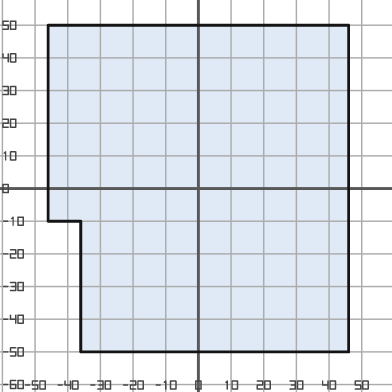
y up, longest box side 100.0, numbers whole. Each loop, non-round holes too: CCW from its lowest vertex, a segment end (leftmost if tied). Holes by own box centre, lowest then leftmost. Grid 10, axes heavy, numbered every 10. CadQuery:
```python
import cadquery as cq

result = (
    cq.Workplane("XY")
    .moveTo(-36.0, -50.0)
    .lineTo(46.0, -50.0)
    .lineTo(46.0, 50.0)
    .lineTo(-46.0, 50.0)
    .lineTo(-46.0, -10.0)
    .lineTo(-36.0, -10.0)
    .close()
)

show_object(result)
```